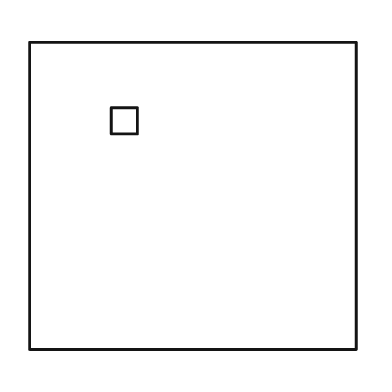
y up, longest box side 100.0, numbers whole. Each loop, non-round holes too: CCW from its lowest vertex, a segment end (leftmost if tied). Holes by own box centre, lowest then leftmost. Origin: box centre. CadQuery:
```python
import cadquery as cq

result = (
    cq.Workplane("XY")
    .moveTo(-50.0, -47.0)
    .lineTo(50.0, -47.0)
    .lineTo(50.0, 47.0)
    .lineTo(-50.0, 47.0)
    .close()
    .moveTo(-25.0, 19.0)
    .lineTo(-17.0, 19.0)
    .lineTo(-17.0, 27.0)
    .lineTo(-25.0, 27.0)
    .close()
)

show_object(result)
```